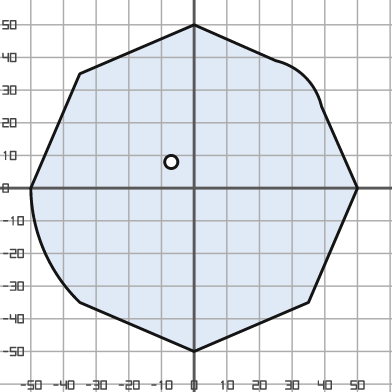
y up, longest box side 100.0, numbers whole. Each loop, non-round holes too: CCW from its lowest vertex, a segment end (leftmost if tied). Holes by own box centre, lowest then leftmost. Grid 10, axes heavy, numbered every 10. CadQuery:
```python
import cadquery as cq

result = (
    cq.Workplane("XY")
    .moveTo(0.0, -50.0)
    .lineTo(35.0, -35.0)
    .lineTo(50.0, 0.0)
    .lineTo(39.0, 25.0)
    .threePointArc((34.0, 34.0), (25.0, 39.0))
    .lineTo(0.0, 50.0)
    .lineTo(-35.0, 35.0)
    .lineTo(-50.0, 0.0)
    .threePointArc((-46.0, -19.0), (-35.0, -35.0))
    .close()
    .moveTo(-7.0, 8.0)
    .circle(2.0)
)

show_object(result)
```